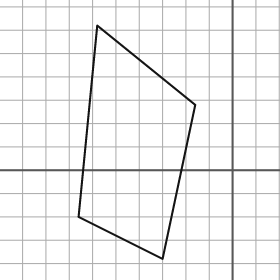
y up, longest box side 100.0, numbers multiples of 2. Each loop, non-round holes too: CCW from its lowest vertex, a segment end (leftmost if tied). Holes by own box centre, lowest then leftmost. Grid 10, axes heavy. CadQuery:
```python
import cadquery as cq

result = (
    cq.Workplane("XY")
    .moveTo(-30.0, -38.0)
    .lineTo(-16.0, 28.0)
    .lineTo(-58.0, 62.0)
    .lineTo(-66.0, -20.0)
    .close()
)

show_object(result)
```